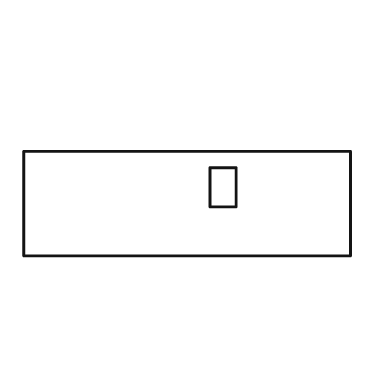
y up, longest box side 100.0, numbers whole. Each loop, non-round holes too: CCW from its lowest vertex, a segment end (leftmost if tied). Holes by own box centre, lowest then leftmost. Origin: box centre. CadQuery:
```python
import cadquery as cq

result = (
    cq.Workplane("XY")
    .moveTo(-50.0, -16.0)
    .lineTo(50.0, -16.0)
    .lineTo(50.0, 16.0)
    .lineTo(-50.0, 16.0)
    .close()
    .moveTo(7.0, -1.0)
    .lineTo(15.0, -1.0)
    .lineTo(15.0, 11.0)
    .lineTo(7.0, 11.0)
    .close()
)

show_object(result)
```